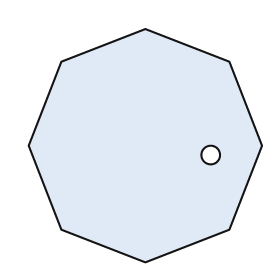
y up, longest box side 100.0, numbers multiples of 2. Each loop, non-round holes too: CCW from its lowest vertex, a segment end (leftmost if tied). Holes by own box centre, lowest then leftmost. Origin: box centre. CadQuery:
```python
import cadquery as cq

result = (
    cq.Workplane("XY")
    .moveTo(0.0, -50.0)
    .lineTo(36.0, -36.0)
    .lineTo(50.0, 0.0)
    .lineTo(36.0, 36.0)
    .lineTo(0.0, 50.0)
    .lineTo(-36.0, 36.0)
    .lineTo(-50.0, 0.0)
    .lineTo(-36.0, -36.0)
    .close()
    .moveTo(28.0, -4.0)
    .circle(4.0)
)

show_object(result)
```